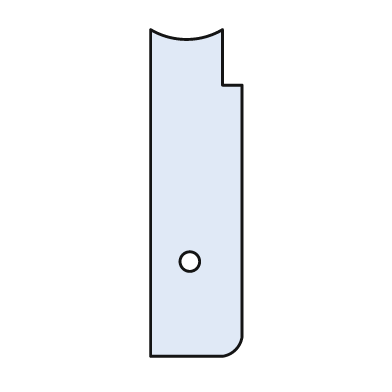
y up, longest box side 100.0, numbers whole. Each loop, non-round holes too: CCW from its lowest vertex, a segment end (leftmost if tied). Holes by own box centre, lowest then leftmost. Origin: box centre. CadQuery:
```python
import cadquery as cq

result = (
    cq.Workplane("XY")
    .moveTo(-14.0, -50.0)
    .lineTo(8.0, -50.0)
    .threePointArc((12.0, -48.0), (14.0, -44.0))
    .lineTo(14.0, 33.0)
    .lineTo(8.0, 33.0)
    .lineTo(8.0, 50.0)
    .threePointArc((-3.0, 47.0), (-14.0, 50.0))
    .close()
    .moveTo(-2.0, -21.0)
    .circle(3.0)
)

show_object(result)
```